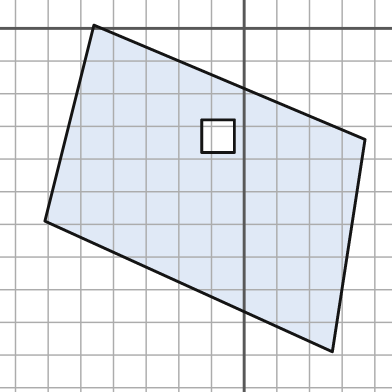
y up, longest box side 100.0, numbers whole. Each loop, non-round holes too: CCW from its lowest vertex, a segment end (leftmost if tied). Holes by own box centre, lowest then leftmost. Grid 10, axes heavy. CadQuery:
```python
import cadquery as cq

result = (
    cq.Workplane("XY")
    .moveTo(27.0, -99.0)
    .lineTo(37.0, -34.0)
    .lineTo(-46.0, 1.0)
    .lineTo(-61.0, -59.0)
    .close()
    .moveTo(-13.0, -38.0)
    .lineTo(-3.0, -38.0)
    .lineTo(-3.0, -28.0)
    .lineTo(-13.0, -28.0)
    .close()
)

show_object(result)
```